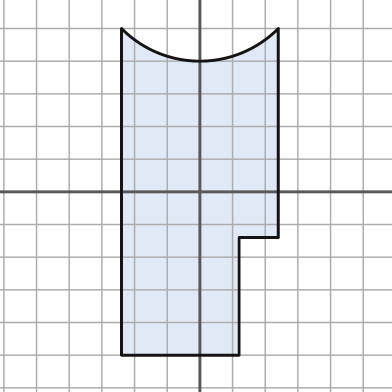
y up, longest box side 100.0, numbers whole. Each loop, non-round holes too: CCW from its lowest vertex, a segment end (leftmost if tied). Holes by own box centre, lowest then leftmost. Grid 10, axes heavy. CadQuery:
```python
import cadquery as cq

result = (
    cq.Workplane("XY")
    .moveTo(-24.0, -50.0)
    .lineTo(12.0, -50.0)
    .lineTo(12.0, -14.0)
    .lineTo(24.0, -14.0)
    .lineTo(24.0, 50.0)
    .threePointArc((0.0, 40.0), (-24.0, 50.0))
    .close()
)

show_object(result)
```